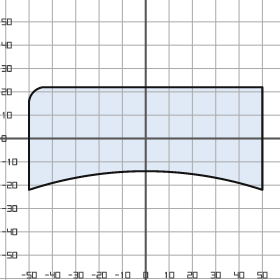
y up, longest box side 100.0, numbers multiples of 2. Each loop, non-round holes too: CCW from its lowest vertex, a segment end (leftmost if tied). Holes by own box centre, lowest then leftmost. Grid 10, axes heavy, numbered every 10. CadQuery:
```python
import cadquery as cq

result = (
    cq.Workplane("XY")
    .moveTo(-50.0, -22.0)
    .threePointArc((0.0, -14.0), (50.0, -22.0))
    .lineTo(50.0, 22.0)
    .lineTo(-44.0, 22.0)
    .threePointArc((-48.0, 20.0), (-50.0, 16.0))
    .close()
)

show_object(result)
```